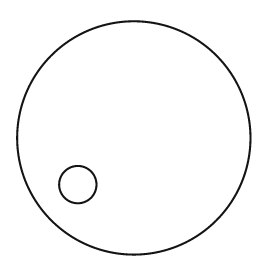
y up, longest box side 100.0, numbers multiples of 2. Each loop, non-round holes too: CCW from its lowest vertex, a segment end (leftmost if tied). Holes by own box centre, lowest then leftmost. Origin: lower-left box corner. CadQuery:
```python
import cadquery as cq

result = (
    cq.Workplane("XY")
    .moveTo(50.0, 50.0)
    .circle(50.0)
    .moveTo(26.0, 30.0)
    .circle(8.0)
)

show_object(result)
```